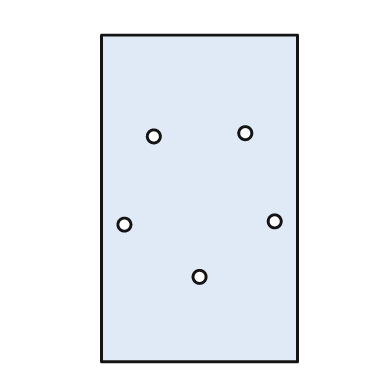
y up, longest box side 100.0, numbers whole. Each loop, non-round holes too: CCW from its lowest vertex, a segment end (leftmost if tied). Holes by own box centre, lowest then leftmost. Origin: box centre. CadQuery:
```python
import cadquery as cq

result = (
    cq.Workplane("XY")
    .moveTo(-30.0, -50.0)
    .lineTo(30.0, -50.0)
    .lineTo(30.0, 50.0)
    .lineTo(-30.0, 50.0)
    .close()
    .moveTo(0.0, -24.0)
    .circle(2.0)
    .moveTo(-23.0, -8.0)
    .circle(2.0)
    .moveTo(23.0, -7.0)
    .circle(2.0)
    .moveTo(-14.0, 19.0)
    .circle(2.0)
    .moveTo(14.0, 20.0)
    .circle(2.0)
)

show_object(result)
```